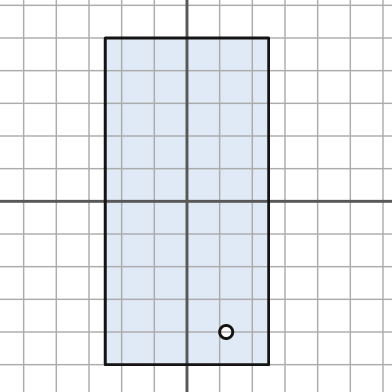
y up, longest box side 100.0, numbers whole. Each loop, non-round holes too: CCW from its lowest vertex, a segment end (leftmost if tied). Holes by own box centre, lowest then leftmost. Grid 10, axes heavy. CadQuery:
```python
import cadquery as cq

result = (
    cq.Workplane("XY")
    .moveTo(-25.0, -50.0)
    .lineTo(25.0, -50.0)
    .lineTo(25.0, 50.0)
    .lineTo(-25.0, 50.0)
    .close()
    .moveTo(12.0, -40.0)
    .circle(2.0)
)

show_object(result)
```